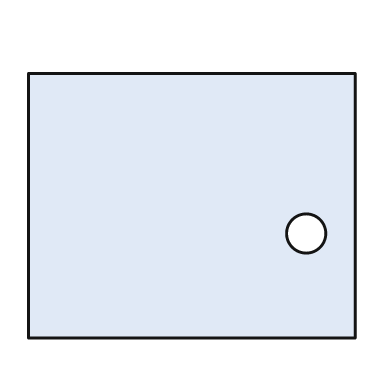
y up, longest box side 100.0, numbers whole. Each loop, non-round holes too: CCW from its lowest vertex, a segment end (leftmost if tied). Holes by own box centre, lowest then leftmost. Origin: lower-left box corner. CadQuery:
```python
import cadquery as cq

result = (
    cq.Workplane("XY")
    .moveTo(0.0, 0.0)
    .lineTo(100.0, 0.0)
    .lineTo(100.0, 81.0)
    .lineTo(0.0, 81.0)
    .close()
    .moveTo(85.0, 32.0)
    .circle(6.0)
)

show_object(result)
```